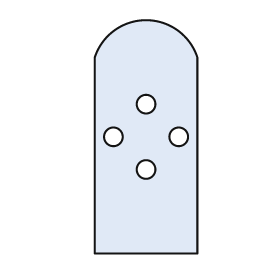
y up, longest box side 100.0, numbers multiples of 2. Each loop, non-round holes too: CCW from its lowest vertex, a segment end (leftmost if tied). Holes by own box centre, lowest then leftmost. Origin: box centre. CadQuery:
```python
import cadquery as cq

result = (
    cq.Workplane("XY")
    .moveTo(-22.0, -50.0)
    .lineTo(22.0, -50.0)
    .lineTo(22.0, 34.0)
    .threePointArc((0.0, 50.0), (-22.0, 34.0))
    .close()
    .moveTo(0.0, -14.0)
    .circle(4.0)
    .moveTo(-14.0, 0.0)
    .circle(4.0)
    .moveTo(14.0, 0.0)
    .circle(4.0)
    .moveTo(0.0, 14.0)
    .circle(4.0)
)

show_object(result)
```